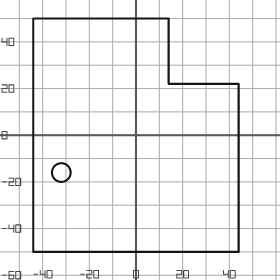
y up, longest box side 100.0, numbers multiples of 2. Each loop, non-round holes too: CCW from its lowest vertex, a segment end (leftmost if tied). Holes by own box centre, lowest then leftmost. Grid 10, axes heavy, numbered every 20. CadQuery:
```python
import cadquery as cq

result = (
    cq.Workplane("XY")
    .moveTo(-44.0, -50.0)
    .lineTo(44.0, -50.0)
    .lineTo(44.0, 22.0)
    .lineTo(14.0, 22.0)
    .lineTo(14.0, 50.0)
    .lineTo(-44.0, 50.0)
    .close()
    .moveTo(-32.0, -16.0)
    .circle(4.0)
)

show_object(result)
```